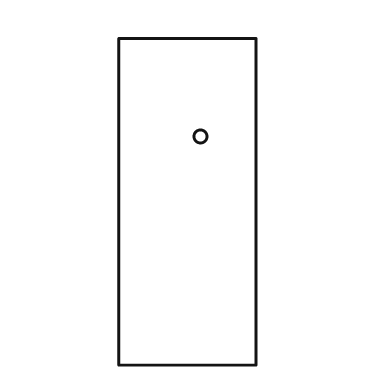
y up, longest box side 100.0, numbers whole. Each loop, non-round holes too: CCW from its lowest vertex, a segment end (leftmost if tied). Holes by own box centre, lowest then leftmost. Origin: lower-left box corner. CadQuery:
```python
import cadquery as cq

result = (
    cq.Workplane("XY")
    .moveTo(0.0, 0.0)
    .lineTo(42.0, 0.0)
    .lineTo(42.0, 100.0)
    .lineTo(0.0, 100.0)
    .close()
    .moveTo(25.0, 70.0)
    .circle(2.0)
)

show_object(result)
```